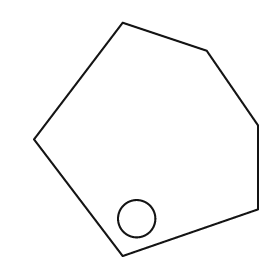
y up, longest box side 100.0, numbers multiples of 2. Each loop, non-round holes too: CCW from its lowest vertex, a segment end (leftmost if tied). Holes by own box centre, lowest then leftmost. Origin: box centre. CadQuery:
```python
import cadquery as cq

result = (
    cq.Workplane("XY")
    .moveTo(-10.0, -50.0)
    .lineTo(48.0, -30.0)
    .lineTo(48.0, 6.0)
    .lineTo(26.0, 38.0)
    .lineTo(-10.0, 50.0)
    .lineTo(-48.0, 0.0)
    .close()
    .moveTo(-4.0, -34.0)
    .circle(8.0)
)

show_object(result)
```